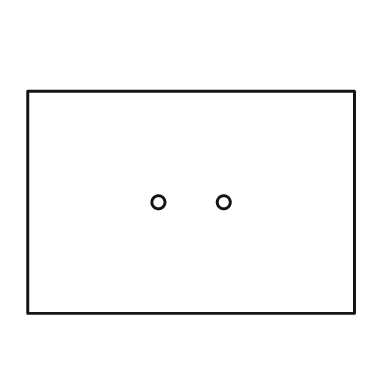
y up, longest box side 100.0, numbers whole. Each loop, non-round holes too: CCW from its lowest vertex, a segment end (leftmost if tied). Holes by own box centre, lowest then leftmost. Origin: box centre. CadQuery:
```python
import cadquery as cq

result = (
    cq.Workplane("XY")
    .moveTo(-50.0, -34.0)
    .lineTo(50.0, -34.0)
    .lineTo(50.0, 34.0)
    .lineTo(-50.0, 34.0)
    .close()
    .moveTo(-10.0, 0.0)
    .circle(2.0)
    .moveTo(10.0, 0.0)
    .circle(2.0)
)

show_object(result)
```